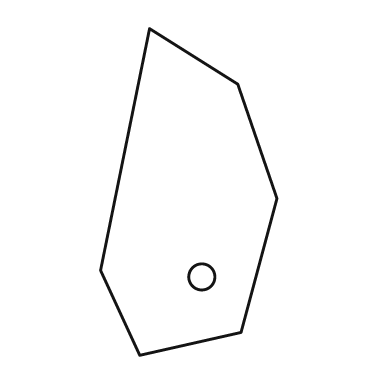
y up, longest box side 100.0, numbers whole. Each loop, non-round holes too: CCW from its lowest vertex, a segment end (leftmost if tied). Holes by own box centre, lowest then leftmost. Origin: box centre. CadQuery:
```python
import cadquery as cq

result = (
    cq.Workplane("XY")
    .moveTo(-15.0, -50.0)
    .lineTo(16.0, -43.0)
    .lineTo(27.0, -2.0)
    .lineTo(15.0, 33.0)
    .lineTo(-12.0, 50.0)
    .lineTo(-27.0, -24.0)
    .close()
    .moveTo(4.0, -26.0)
    .circle(4.0)
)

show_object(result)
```